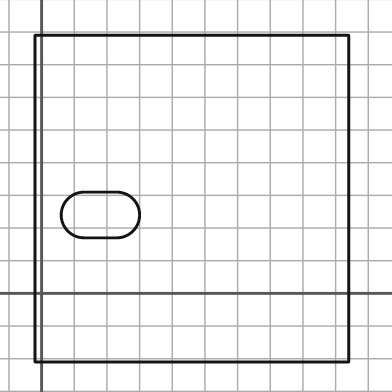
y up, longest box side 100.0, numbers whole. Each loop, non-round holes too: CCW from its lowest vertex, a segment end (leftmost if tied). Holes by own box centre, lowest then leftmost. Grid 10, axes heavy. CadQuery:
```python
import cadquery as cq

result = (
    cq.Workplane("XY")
    .moveTo(-2.0, -21.0)
    .lineTo(94.0, -21.0)
    .lineTo(94.0, 79.0)
    .lineTo(-2.0, 79.0)
    .close()
    .moveTo(13.0, 17.0)
    .lineTo(23.0, 17.0)
    .threePointArc((30.0, 24.0), (23.0, 31.0))
    .lineTo(13.0, 31.0)
    .threePointArc((6.0, 24.0), (13.0, 17.0))
    .close()
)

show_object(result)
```